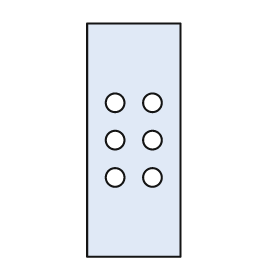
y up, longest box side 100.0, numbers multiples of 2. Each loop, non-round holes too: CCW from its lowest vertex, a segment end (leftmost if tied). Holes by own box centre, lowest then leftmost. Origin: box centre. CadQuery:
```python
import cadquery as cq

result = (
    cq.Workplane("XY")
    .moveTo(-20.0, -50.0)
    .lineTo(20.0, -50.0)
    .lineTo(20.0, 50.0)
    .lineTo(-20.0, 50.0)
    .close()
    .moveTo(-8.0, -16.0)
    .circle(4.0)
    .moveTo(8.0, -16.0)
    .circle(4.0)
    .moveTo(-8.0, 0.0)
    .circle(4.0)
    .moveTo(8.0, 0.0)
    .circle(4.0)
    .moveTo(-8.0, 16.0)
    .circle(4.0)
    .moveTo(8.0, 16.0)
    .circle(4.0)
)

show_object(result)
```